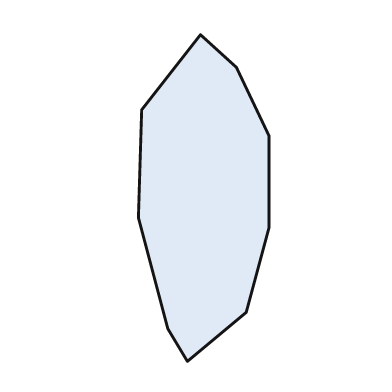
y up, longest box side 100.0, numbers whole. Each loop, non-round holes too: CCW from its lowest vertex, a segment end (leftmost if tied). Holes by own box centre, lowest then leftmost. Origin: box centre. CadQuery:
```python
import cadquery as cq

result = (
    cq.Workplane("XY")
    .moveTo(-5.0, -50.0)
    .lineTo(13.0, -35.0)
    .lineTo(20.0, -9.0)
    .lineTo(20.0, 19.0)
    .lineTo(10.0, 40.0)
    .lineTo(-1.0, 50.0)
    .lineTo(-19.0, 27.0)
    .lineTo(-20.0, -6.0)
    .lineTo(-11.0, -40.0)
    .close()
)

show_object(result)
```